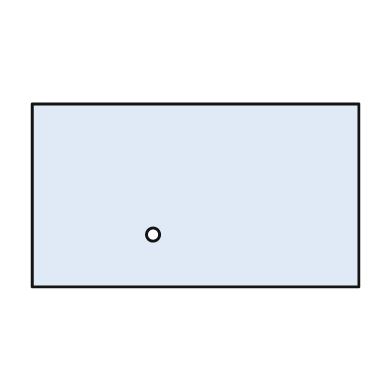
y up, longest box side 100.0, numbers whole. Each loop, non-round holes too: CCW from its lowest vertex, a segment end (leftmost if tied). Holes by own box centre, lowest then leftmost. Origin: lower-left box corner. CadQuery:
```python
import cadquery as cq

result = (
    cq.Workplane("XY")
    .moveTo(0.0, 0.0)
    .lineTo(100.0, 0.0)
    .lineTo(100.0, 56.0)
    .lineTo(0.0, 56.0)
    .close()
    .moveTo(37.0, 16.0)
    .circle(2.0)
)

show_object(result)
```